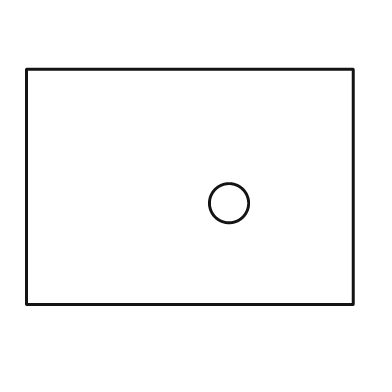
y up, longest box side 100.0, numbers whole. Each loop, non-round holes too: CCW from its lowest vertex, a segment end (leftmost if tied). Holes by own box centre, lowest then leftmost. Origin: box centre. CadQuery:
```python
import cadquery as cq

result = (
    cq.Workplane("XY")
    .moveTo(-50.0, -36.0)
    .lineTo(50.0, -36.0)
    .lineTo(50.0, 36.0)
    .lineTo(-50.0, 36.0)
    .close()
    .moveTo(12.0, -5.0)
    .circle(6.0)
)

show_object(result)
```